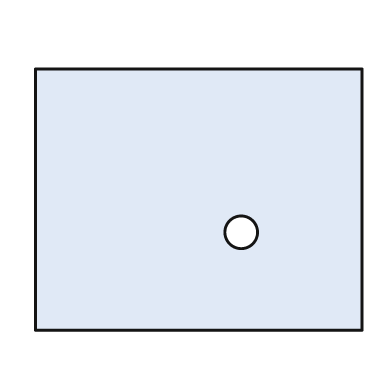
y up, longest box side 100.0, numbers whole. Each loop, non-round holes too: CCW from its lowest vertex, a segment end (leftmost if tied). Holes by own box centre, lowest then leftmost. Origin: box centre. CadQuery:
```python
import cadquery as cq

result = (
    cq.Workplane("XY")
    .moveTo(-50.0, -40.0)
    .lineTo(50.0, -40.0)
    .lineTo(50.0, 40.0)
    .lineTo(-50.0, 40.0)
    .close()
    .moveTo(13.0, -10.0)
    .circle(5.0)
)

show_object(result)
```